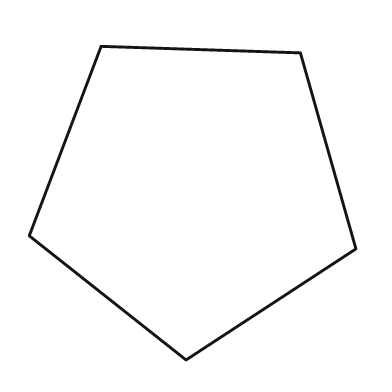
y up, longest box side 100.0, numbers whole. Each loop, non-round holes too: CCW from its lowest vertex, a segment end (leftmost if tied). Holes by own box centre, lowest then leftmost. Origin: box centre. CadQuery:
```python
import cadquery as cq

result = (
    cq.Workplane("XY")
    .moveTo(-2.0, -48.0)
    .lineTo(50.0, -14.0)
    .lineTo(33.0, 46.0)
    .lineTo(-28.0, 48.0)
    .lineTo(-50.0, -10.0)
    .close()
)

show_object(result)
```